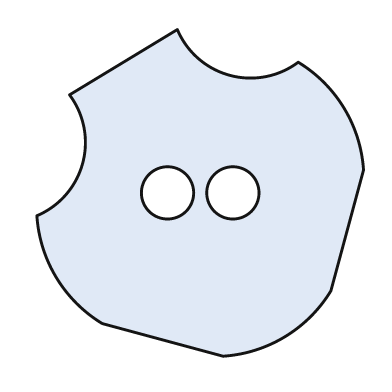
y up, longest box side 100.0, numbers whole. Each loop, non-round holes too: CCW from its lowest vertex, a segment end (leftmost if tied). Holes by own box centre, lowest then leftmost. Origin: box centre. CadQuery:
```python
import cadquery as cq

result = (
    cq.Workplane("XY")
    .moveTo(7.0, -50.0)
    .threePointArc((26.0, -44.0), (40.0, -30.0))
    .lineTo(50.0, 7.0)
    .threePointArc((44.0, 26.0), (30.0, 40.0))
    .threePointArc((9.0, 36.0), (-7.0, 50.0))
    .lineTo(-40.0, 30.0)
    .threePointArc((-36.0, 9.0), (-50.0, -7.0))
    .threePointArc((-44.0, -26.0), (-30.0, -40.0))
    .close()
    .moveTo(-10.0, 0.0)
    .circle(8.0)
    .moveTo(10.0, 0.0)
    .circle(8.0)
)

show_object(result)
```